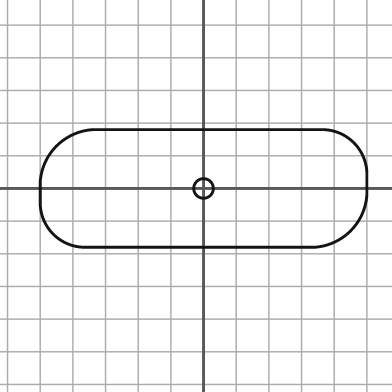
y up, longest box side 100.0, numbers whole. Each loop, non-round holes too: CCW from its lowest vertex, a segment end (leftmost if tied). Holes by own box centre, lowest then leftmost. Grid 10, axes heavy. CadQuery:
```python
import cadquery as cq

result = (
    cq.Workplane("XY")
    .moveTo(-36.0, -18.0)
    .lineTo(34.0, -18.0)
    .threePointArc((45.0, -13.0), (50.0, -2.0))
    .lineTo(50.0, 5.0)
    .threePointArc((46.0, 14.0), (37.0, 18.0))
    .lineTo(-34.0, 18.0)
    .threePointArc((-45.0, 13.0), (-50.0, 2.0))
    .lineTo(-50.0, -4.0)
    .threePointArc((-46.0, -14.0), (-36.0, -18.0))
    .close()
    .moveTo(0.0, 0.0)
    .circle(3.0)
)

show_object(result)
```